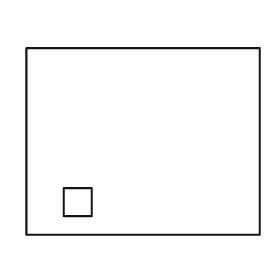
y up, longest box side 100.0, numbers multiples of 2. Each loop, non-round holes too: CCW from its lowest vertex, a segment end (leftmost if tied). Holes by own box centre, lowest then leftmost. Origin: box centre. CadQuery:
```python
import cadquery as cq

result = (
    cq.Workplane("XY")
    .moveTo(-50.0, -40.0)
    .lineTo(50.0, -40.0)
    .lineTo(50.0, 40.0)
    .lineTo(-50.0, 40.0)
    .close()
    .moveTo(-34.0, -32.0)
    .lineTo(-22.0, -32.0)
    .lineTo(-22.0, -20.0)
    .lineTo(-34.0, -20.0)
    .close()
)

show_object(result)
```